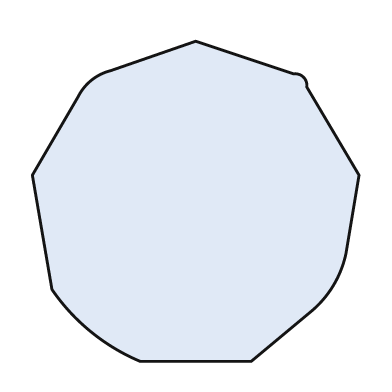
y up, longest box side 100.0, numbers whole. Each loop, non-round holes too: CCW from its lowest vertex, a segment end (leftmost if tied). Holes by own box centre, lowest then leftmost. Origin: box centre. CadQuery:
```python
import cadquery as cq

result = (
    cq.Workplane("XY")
    .moveTo(-17.0, -49.0)
    .lineTo(17.0, -49.0)
    .lineTo(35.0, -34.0)
    .threePointArc((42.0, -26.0), (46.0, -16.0))
    .lineTo(50.0, 8.0)
    .lineTo(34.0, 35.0)
    .threePointArc((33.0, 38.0), (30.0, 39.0))
    .lineTo(0.0, 49.0)
    .lineTo(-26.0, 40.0)
    .threePointArc((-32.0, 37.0), (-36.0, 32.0))
    .lineTo(-50.0, 8.0)
    .lineTo(-44.0, -27.0)
    .threePointArc((-32.0, -40.0), (-17.0, -49.0))
    .close()
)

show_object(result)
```